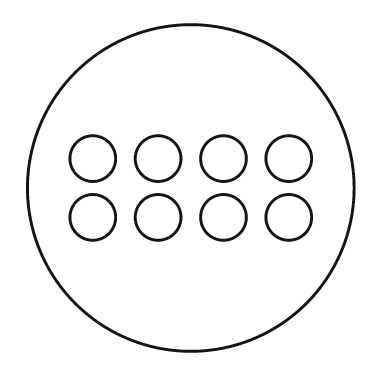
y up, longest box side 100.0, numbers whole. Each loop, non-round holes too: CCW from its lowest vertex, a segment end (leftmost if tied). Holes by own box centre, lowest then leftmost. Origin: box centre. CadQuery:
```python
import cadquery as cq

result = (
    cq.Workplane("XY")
    .moveTo(0.0, 0.0)
    .circle(50.0)
    .moveTo(-30.0, -9.0)
    .circle(7.0)
    .moveTo(-10.0, -9.0)
    .circle(7.0)
    .moveTo(10.0, -9.0)
    .circle(7.0)
    .moveTo(30.0, -9.0)
    .circle(7.0)
    .moveTo(-30.0, 9.0)
    .circle(7.0)
    .moveTo(-10.0, 9.0)
    .circle(7.0)
    .moveTo(10.0, 9.0)
    .circle(7.0)
    .moveTo(30.0, 9.0)
    .circle(7.0)
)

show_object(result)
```